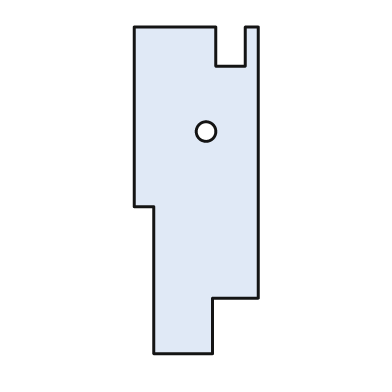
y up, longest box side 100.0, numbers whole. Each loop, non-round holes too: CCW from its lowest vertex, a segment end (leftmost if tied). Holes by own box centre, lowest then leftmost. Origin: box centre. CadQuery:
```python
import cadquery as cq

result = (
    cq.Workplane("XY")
    .moveTo(-13.0, -50.0)
    .lineTo(5.0, -50.0)
    .lineTo(5.0, -33.0)
    .lineTo(19.0, -33.0)
    .lineTo(19.0, 50.0)
    .lineTo(15.0, 50.0)
    .lineTo(15.0, 38.0)
    .lineTo(6.0, 38.0)
    .lineTo(6.0, 50.0)
    .lineTo(-19.0, 50.0)
    .lineTo(-19.0, -5.0)
    .lineTo(-13.0, -5.0)
    .close()
    .moveTo(3.0, 18.0)
    .circle(3.0)
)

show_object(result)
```